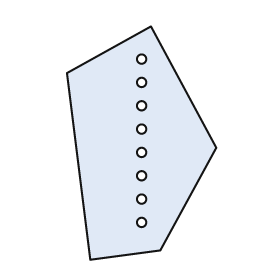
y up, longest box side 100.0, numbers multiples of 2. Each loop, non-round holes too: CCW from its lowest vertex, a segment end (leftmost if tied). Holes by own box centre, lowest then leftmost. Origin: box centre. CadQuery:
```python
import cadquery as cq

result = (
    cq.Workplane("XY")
    .moveTo(-22.0, -50.0)
    .lineTo(8.0, -46.0)
    .lineTo(32.0, -2.0)
    .lineTo(4.0, 50.0)
    .lineTo(-32.0, 30.0)
    .close()
    .moveTo(0.0, -34.0)
    .circle(2.0)
    .moveTo(0.0, -24.0)
    .circle(2.0)
    .moveTo(0.0, -14.0)
    .circle(2.0)
    .moveTo(0.0, -4.0)
    .circle(2.0)
    .moveTo(0.0, 6.0)
    .circle(2.0)
    .moveTo(0.0, 16.0)
    .circle(2.0)
    .moveTo(0.0, 26.0)
    .circle(2.0)
    .moveTo(0.0, 36.0)
    .circle(2.0)
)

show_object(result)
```